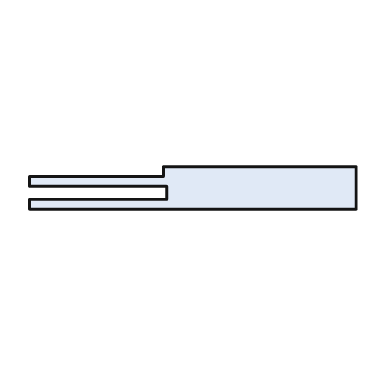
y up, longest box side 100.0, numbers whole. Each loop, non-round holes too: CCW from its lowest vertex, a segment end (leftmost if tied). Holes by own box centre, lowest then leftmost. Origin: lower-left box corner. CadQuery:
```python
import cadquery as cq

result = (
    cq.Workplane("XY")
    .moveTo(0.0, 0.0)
    .lineTo(100.0, 0.0)
    .lineTo(100.0, 13.0)
    .lineTo(41.0, 13.0)
    .lineTo(41.0, 10.0)
    .lineTo(0.0, 10.0)
    .lineTo(0.0, 7.0)
    .lineTo(42.0, 7.0)
    .lineTo(42.0, 3.0)
    .lineTo(0.0, 3.0)
    .close()
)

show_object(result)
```